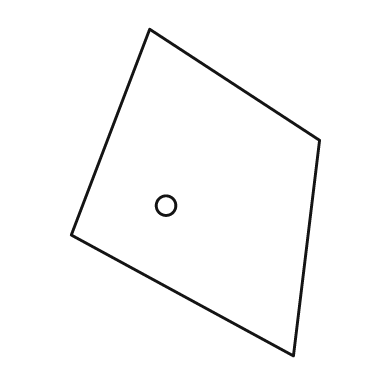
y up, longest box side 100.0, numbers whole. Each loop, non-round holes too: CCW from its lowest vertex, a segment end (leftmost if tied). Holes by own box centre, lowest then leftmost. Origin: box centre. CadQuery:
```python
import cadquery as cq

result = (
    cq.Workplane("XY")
    .moveTo(30.0, -50.0)
    .lineTo(38.0, 16.0)
    .lineTo(-14.0, 50.0)
    .lineTo(-38.0, -13.0)
    .close()
    .moveTo(-9.0, -4.0)
    .circle(3.0)
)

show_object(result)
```